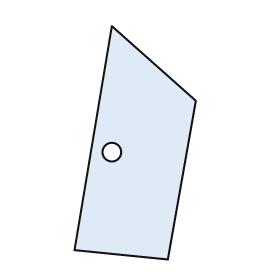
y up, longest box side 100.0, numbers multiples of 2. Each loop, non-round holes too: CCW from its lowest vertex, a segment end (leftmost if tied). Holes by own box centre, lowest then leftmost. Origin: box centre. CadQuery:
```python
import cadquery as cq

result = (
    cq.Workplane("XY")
    .moveTo(14.0, -50.0)
    .lineTo(26.0, 18.0)
    .lineTo(-10.0, 50.0)
    .lineTo(-26.0, -46.0)
    .close()
    .moveTo(-10.0, -4.0)
    .circle(4.0)
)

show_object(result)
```